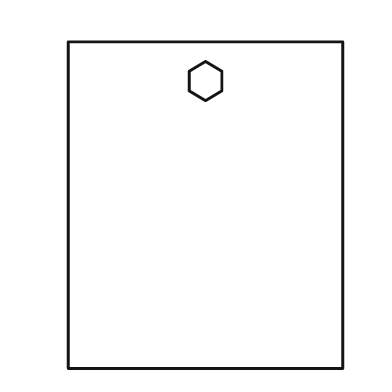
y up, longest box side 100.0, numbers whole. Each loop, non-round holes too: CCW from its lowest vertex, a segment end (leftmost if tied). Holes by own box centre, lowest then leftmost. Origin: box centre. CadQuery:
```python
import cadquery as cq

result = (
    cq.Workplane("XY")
    .moveTo(-42.0, -50.0)
    .lineTo(42.0, -50.0)
    .lineTo(42.0, 50.0)
    .lineTo(-42.0, 50.0)
    .close()
    .moveTo(0.0, 32.0)
    .lineTo(5.0, 35.0)
    .lineTo(5.0, 41.0)
    .lineTo(0.0, 44.0)
    .lineTo(-5.0, 41.0)
    .lineTo(-5.0, 35.0)
    .close()
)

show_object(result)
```